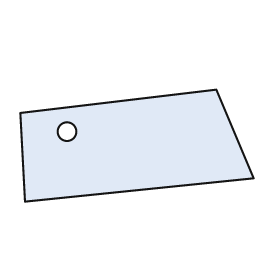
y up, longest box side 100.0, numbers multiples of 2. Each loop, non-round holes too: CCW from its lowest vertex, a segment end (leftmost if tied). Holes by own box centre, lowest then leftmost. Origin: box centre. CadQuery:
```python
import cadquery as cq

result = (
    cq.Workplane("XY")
    .moveTo(-48.0, -24.0)
    .lineTo(50.0, -14.0)
    .lineTo(34.0, 24.0)
    .lineTo(-50.0, 14.0)
    .close()
    .moveTo(-30.0, 6.0)
    .circle(4.0)
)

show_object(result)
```